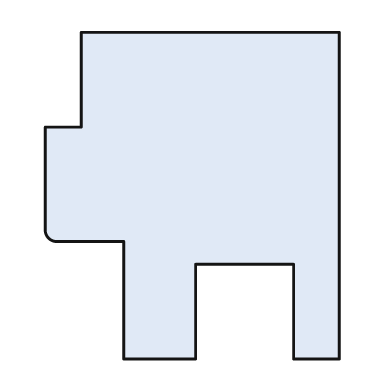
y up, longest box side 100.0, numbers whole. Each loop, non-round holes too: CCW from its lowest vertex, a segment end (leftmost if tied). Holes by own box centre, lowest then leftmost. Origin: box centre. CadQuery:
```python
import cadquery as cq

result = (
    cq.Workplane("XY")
    .moveTo(-21.0, -50.0)
    .lineTo(1.0, -50.0)
    .lineTo(1.0, -21.0)
    .lineTo(31.0, -21.0)
    .lineTo(31.0, -50.0)
    .lineTo(45.0, -50.0)
    .lineTo(45.0, 50.0)
    .lineTo(-34.0, 50.0)
    .lineTo(-34.0, 21.0)
    .lineTo(-45.0, 21.0)
    .lineTo(-45.0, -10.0)
    .threePointArc((-44.0, -13.0), (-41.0, -14.0))
    .lineTo(-21.0, -14.0)
    .close()
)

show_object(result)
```